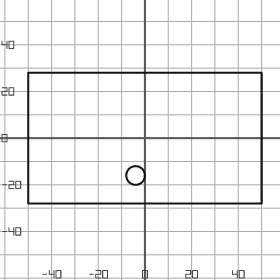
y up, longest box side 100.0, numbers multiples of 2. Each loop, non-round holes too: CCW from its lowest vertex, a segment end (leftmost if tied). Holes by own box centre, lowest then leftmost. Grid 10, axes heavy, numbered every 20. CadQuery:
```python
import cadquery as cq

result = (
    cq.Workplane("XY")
    .moveTo(-50.0, -28.0)
    .lineTo(50.0, -28.0)
    .lineTo(50.0, 28.0)
    .lineTo(-50.0, 28.0)
    .close()
    .moveTo(-4.0, -16.0)
    .circle(4.0)
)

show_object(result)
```